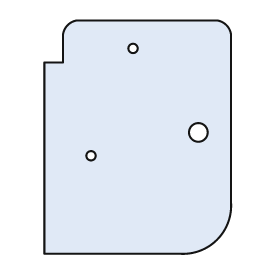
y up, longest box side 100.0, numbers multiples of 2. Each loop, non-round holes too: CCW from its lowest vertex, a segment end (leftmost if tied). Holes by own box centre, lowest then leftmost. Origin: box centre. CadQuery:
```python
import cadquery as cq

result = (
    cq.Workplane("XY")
    .moveTo(-40.0, -50.0)
    .lineTo(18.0, -50.0)
    .threePointArc((34.0, -44.0), (40.0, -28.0))
    .lineTo(40.0, 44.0)
    .threePointArc((38.0, 48.0), (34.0, 50.0))
    .lineTo(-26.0, 50.0)
    .threePointArc((-30.0, 48.0), (-32.0, 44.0))
    .lineTo(-32.0, 32.0)
    .lineTo(-40.0, 32.0)
    .close()
    .moveTo(-20.0, -8.0)
    .circle(2.0)
    .moveTo(26.0, 2.0)
    .circle(4.0)
    .moveTo(-2.0, 38.0)
    .circle(2.0)
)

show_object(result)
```